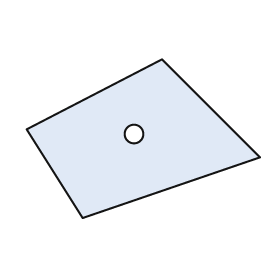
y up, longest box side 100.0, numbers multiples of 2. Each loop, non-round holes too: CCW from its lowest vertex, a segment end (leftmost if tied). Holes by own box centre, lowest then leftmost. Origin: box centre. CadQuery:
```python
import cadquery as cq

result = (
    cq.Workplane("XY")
    .moveTo(-26.0, -34.0)
    .lineTo(50.0, -8.0)
    .lineTo(8.0, 34.0)
    .lineTo(-50.0, 4.0)
    .close()
    .moveTo(-4.0, 2.0)
    .circle(4.0)
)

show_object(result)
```